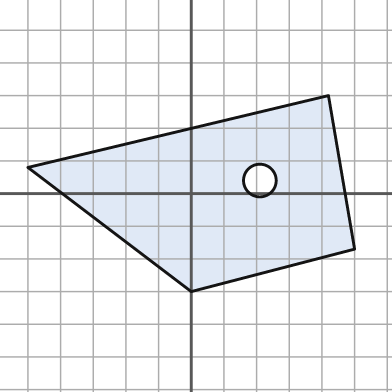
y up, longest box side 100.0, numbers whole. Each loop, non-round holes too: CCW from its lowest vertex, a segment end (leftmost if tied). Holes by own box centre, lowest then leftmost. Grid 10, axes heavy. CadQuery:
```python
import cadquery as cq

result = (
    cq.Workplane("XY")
    .moveTo(0.0, -30.0)
    .lineTo(50.0, -17.0)
    .lineTo(42.0, 30.0)
    .lineTo(-50.0, 8.0)
    .close()
    .moveTo(21.0, 4.0)
    .circle(5.0)
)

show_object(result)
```